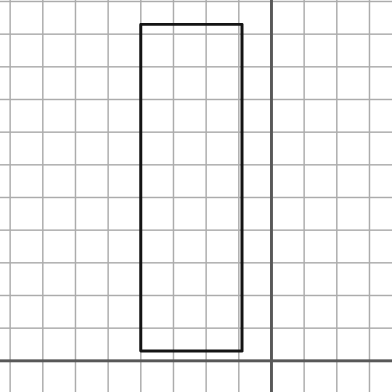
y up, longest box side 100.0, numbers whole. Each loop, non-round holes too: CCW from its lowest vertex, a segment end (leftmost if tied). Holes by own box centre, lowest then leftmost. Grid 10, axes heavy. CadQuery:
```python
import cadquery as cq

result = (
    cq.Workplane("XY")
    .moveTo(-40.0, 3.0)
    .lineTo(-9.0, 3.0)
    .lineTo(-9.0, 103.0)
    .lineTo(-40.0, 103.0)
    .close()
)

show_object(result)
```